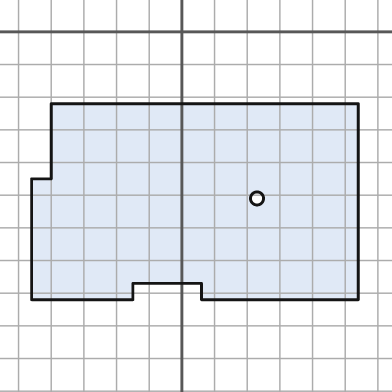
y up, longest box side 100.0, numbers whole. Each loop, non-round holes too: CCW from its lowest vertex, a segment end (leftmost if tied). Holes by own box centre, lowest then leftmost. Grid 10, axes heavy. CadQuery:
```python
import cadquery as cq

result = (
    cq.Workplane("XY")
    .moveTo(-46.0, -82.0)
    .lineTo(-15.0, -82.0)
    .lineTo(-15.0, -77.0)
    .lineTo(6.0, -77.0)
    .lineTo(6.0, -82.0)
    .lineTo(54.0, -82.0)
    .lineTo(54.0, -22.0)
    .lineTo(-40.0, -22.0)
    .lineTo(-40.0, -45.0)
    .lineTo(-46.0, -45.0)
    .close()
    .moveTo(23.0, -51.0)
    .circle(2.0)
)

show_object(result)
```